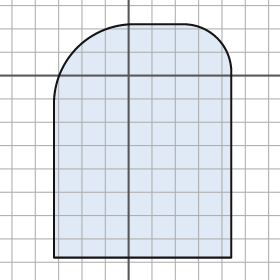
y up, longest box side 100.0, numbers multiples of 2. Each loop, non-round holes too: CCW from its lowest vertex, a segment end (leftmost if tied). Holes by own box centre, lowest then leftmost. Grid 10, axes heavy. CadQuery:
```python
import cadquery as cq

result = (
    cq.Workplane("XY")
    .moveTo(-32.0, -78.0)
    .lineTo(44.0, -78.0)
    .lineTo(44.0, 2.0)
    .threePointArc((38.0, 16.0), (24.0, 22.0))
    .lineTo(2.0, 22.0)
    .threePointArc((-22.0, 12.0), (-32.0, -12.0))
    .close()
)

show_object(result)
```